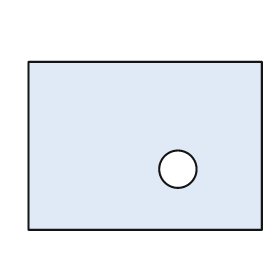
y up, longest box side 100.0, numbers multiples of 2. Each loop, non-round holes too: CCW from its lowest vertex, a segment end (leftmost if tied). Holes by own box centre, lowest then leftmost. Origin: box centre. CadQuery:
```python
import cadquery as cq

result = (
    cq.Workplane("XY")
    .moveTo(-50.0, -36.0)
    .lineTo(50.0, -36.0)
    .lineTo(50.0, 36.0)
    .lineTo(-50.0, 36.0)
    .close()
    .moveTo(14.0, -10.0)
    .circle(8.0)
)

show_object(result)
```